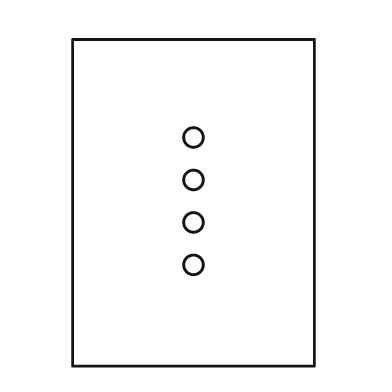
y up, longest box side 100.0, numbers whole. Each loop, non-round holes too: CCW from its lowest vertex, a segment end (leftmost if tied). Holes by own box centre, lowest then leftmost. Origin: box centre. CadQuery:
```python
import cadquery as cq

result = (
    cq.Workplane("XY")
    .moveTo(-37.0, -50.0)
    .lineTo(37.0, -50.0)
    .lineTo(37.0, 50.0)
    .lineTo(-37.0, 50.0)
    .close()
    .moveTo(0.0, -19.0)
    .circle(3.0)
    .moveTo(0.0, -6.0)
    .circle(3.0)
    .moveTo(0.0, 7.0)
    .circle(3.0)
    .moveTo(0.0, 20.0)
    .circle(3.0)
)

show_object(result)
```